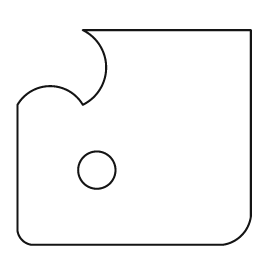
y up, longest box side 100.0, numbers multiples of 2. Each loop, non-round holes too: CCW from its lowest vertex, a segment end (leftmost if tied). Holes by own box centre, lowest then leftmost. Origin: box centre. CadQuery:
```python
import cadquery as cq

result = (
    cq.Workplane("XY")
    .moveTo(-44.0, -46.0)
    .lineTo(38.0, -46.0)
    .threePointArc((46.0, -42.0), (50.0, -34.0))
    .lineTo(50.0, 46.0)
    .lineTo(-22.0, 46.0)
    .threePointArc((-12.0, 30.0), (-22.0, 14.0))
    .threePointArc((-36.0, 22.0), (-50.0, 14.0))
    .lineTo(-50.0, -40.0)
    .threePointArc((-48.0, -44.0), (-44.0, -46.0))
    .close()
    .moveTo(-16.0, -14.0)
    .circle(8.0)
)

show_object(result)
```